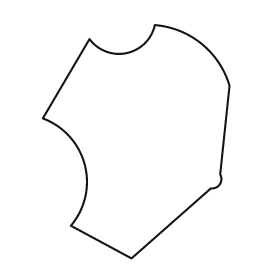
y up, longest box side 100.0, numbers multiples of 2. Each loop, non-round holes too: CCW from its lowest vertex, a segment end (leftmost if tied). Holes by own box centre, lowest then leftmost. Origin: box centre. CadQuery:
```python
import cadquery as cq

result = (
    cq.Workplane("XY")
    .moveTo(-2.0, -50.0)
    .lineTo(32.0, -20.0)
    .threePointArc((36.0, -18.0), (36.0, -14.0))
    .lineTo(40.0, 24.0)
    .threePointArc((28.0, 42.0), (8.0, 50.0))
    .threePointArc((-4.0, 38.0), (-20.0, 44.0))
    .lineTo(-40.0, 10.0)
    .threePointArc((-22.0, -10.0), (-28.0, -36.0))
    .close()
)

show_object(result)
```